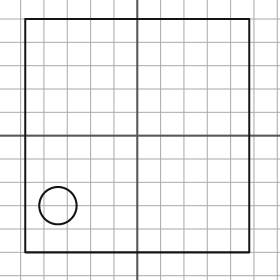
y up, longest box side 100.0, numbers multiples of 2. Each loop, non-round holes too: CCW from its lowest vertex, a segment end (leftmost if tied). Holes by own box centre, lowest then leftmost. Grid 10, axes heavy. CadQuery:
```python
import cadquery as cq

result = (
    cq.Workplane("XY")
    .moveTo(-48.0, -50.0)
    .lineTo(48.0, -50.0)
    .lineTo(48.0, 50.0)
    .lineTo(-48.0, 50.0)
    .close()
    .moveTo(-34.0, -30.0)
    .circle(8.0)
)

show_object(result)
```